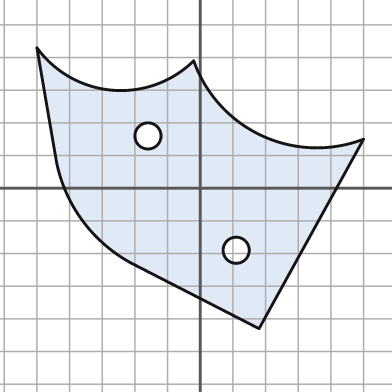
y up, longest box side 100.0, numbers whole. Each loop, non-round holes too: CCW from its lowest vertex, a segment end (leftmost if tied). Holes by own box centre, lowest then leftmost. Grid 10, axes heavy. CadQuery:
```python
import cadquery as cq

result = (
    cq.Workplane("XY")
    .moveTo(18.0, -43.0)
    .lineTo(50.0, 15.0)
    .threePointArc((19.0, 16.0), (-2.0, 39.0))
    .threePointArc((-27.0, 30.0), (-50.0, 43.0))
    .lineTo(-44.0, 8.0)
    .threePointArc((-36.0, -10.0), (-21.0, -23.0))
    .close()
    .moveTo(11.0, -19.0)
    .circle(4.0)
    .moveTo(-16.0, 16.0)
    .circle(4.0)
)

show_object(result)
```